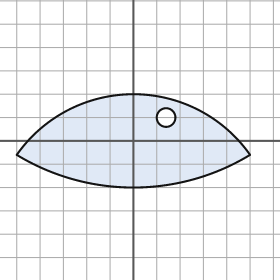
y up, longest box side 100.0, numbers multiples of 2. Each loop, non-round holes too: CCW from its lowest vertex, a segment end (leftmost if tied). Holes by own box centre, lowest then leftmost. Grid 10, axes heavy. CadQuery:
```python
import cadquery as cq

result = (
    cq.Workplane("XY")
    .moveTo(-50.0, -6.0)
    .threePointArc((0.0, -20.0), (50.0, -6.0))
    .threePointArc((0.0, 20.0), (-50.0, -6.0))
    .close()
    .moveTo(14.0, 10.0)
    .circle(4.0)
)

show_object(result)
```